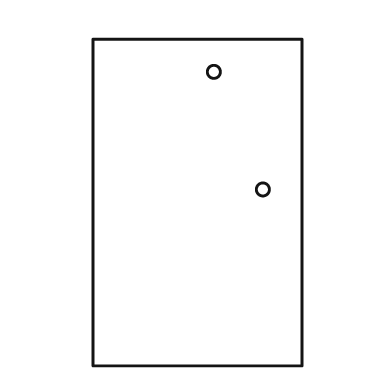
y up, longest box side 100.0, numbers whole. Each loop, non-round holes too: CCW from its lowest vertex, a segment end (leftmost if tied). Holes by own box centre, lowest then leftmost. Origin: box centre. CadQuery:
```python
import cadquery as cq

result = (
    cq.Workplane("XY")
    .moveTo(-32.0, -50.0)
    .lineTo(32.0, -50.0)
    .lineTo(32.0, 50.0)
    .lineTo(-32.0, 50.0)
    .close()
    .moveTo(20.0, 4.0)
    .circle(2.0)
    .moveTo(5.0, 40.0)
    .circle(2.0)
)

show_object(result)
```